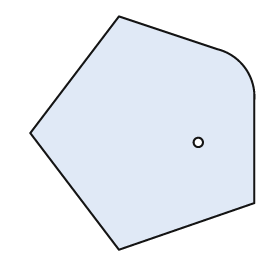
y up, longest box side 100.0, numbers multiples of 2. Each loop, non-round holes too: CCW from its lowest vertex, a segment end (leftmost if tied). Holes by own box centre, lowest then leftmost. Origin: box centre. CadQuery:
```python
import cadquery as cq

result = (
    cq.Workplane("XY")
    .moveTo(-10.0, -50.0)
    .lineTo(48.0, -30.0)
    .lineTo(48.0, 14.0)
    .threePointArc((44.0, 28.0), (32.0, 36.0))
    .lineTo(-10.0, 50.0)
    .lineTo(-48.0, 0.0)
    .close()
    .moveTo(24.0, -4.0)
    .circle(2.0)
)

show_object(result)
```